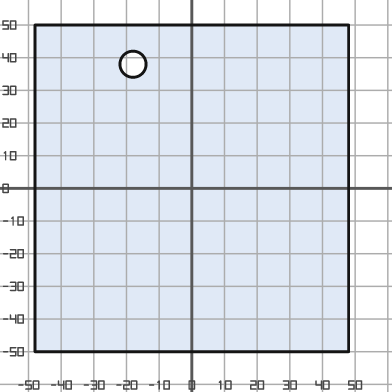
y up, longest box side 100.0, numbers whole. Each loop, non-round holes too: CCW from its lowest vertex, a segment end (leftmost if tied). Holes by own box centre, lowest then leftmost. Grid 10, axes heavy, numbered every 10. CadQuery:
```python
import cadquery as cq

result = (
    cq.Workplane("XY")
    .moveTo(-48.0, -50.0)
    .lineTo(48.0, -50.0)
    .lineTo(48.0, 50.0)
    .lineTo(-48.0, 50.0)
    .close()
    .moveTo(-18.0, 38.0)
    .circle(4.0)
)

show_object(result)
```